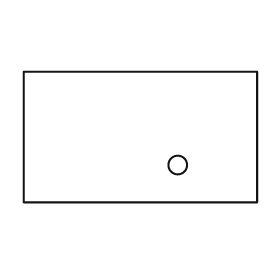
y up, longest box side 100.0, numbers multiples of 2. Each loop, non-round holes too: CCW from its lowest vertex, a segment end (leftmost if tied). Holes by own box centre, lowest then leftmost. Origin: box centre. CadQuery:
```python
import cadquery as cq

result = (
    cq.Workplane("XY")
    .moveTo(-50.0, -28.0)
    .lineTo(50.0, -28.0)
    .lineTo(50.0, 28.0)
    .lineTo(-50.0, 28.0)
    .close()
    .moveTo(16.0, -12.0)
    .circle(4.0)
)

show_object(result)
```